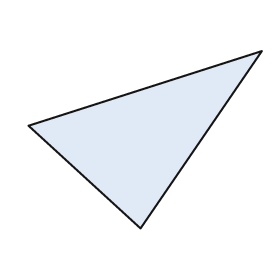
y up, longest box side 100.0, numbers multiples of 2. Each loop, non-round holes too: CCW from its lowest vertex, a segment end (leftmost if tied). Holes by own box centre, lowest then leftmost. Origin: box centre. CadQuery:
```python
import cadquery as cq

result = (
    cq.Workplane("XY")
    .moveTo(-2.0, -38.0)
    .lineTo(50.0, 38.0)
    .lineTo(-50.0, 6.0)
    .close()
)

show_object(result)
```